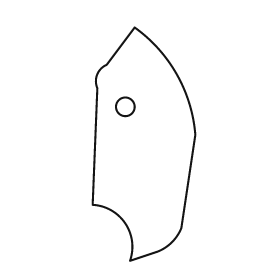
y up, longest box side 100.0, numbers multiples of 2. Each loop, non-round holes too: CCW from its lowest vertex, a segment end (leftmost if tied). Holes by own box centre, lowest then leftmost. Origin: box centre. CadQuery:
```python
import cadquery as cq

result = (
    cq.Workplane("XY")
    .moveTo(-6.0, -50.0)
    .lineTo(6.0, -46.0)
    .threePointArc((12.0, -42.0), (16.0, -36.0))
    .lineTo(22.0, 4.0)
    .threePointArc((14.0, 30.0), (-4.0, 50.0))
    .lineTo(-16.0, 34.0)
    .threePointArc((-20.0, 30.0), (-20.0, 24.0))
    .lineTo(-22.0, -26.0)
    .threePointArc((-8.0, -34.0), (-6.0, -50.0))
    .close()
    .moveTo(-8.0, 16.0)
    .circle(4.0)
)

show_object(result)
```